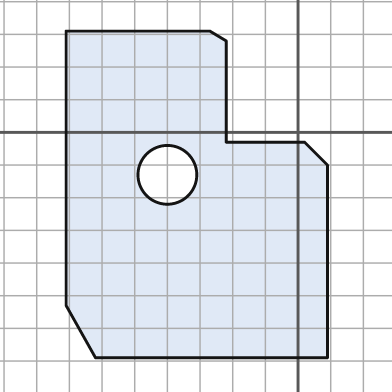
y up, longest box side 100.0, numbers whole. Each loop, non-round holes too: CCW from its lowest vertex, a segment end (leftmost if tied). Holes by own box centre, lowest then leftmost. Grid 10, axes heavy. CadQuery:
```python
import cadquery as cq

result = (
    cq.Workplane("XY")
    .moveTo(-62.0, -69.0)
    .lineTo(9.0, -69.0)
    .lineTo(9.0, -10.0)
    .lineTo(2.0, -3.0)
    .lineTo(-22.0, -3.0)
    .lineTo(-22.0, 28.0)
    .lineTo(-27.0, 31.0)
    .lineTo(-71.0, 31.0)
    .lineTo(-71.0, -53.0)
    .close()
    .moveTo(-40.0, -13.0)
    .circle(9.0)
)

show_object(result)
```